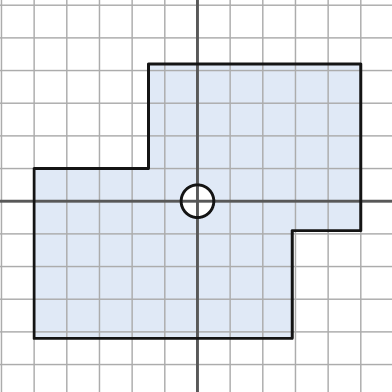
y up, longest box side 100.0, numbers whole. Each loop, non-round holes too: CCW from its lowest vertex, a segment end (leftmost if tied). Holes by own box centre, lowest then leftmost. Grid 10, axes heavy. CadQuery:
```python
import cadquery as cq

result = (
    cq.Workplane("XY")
    .moveTo(-50.0, -42.0)
    .lineTo(29.0, -42.0)
    .lineTo(29.0, -9.0)
    .lineTo(50.0, -9.0)
    .lineTo(50.0, 42.0)
    .lineTo(-15.0, 42.0)
    .lineTo(-15.0, 10.0)
    .lineTo(-50.0, 10.0)
    .close()
    .moveTo(0.0, 0.0)
    .circle(5.0)
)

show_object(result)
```